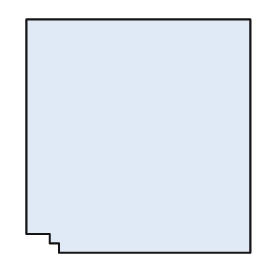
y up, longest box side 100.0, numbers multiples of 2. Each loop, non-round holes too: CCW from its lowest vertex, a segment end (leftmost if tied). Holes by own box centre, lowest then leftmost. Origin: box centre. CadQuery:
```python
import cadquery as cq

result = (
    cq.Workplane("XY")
    .moveTo(-34.0, -50.0)
    .lineTo(48.0, -50.0)
    .lineTo(48.0, 50.0)
    .lineTo(-48.0, 50.0)
    .lineTo(-48.0, -42.0)
    .lineTo(-38.0, -42.0)
    .lineTo(-38.0, -46.0)
    .lineTo(-34.0, -46.0)
    .close()
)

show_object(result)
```